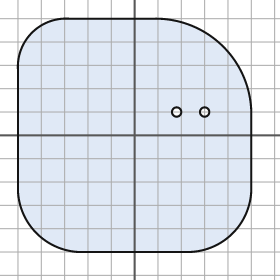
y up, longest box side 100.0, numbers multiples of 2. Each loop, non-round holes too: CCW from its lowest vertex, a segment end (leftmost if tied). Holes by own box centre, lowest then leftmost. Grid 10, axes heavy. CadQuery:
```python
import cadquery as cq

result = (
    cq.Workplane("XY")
    .moveTo(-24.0, -50.0)
    .lineTo(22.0, -50.0)
    .threePointArc((42.0, -42.0), (50.0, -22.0))
    .lineTo(50.0, 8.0)
    .threePointArc((38.0, 38.0), (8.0, 50.0))
    .lineTo(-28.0, 50.0)
    .threePointArc((-44.0, 44.0), (-50.0, 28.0))
    .lineTo(-50.0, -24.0)
    .threePointArc((-42.0, -42.0), (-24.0, -50.0))
    .close()
    .moveTo(18.0, 10.0)
    .circle(2.0)
    .moveTo(30.0, 10.0)
    .circle(2.0)
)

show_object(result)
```